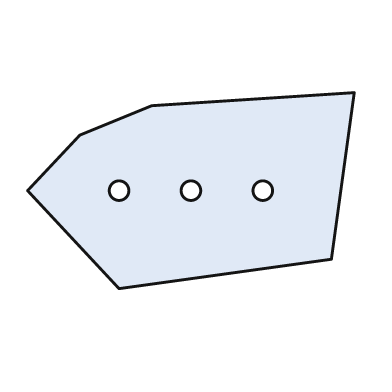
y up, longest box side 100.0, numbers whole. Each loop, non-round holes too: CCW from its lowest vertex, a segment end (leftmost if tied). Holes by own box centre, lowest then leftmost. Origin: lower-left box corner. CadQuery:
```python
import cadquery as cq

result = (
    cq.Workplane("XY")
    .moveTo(28.0, 0.0)
    .lineTo(93.0, 9.0)
    .lineTo(100.0, 60.0)
    .lineTo(38.0, 56.0)
    .lineTo(16.0, 47.0)
    .lineTo(0.0, 30.0)
    .close()
    .moveTo(28.0, 30.0)
    .circle(3.0)
    .moveTo(50.0, 30.0)
    .circle(3.0)
    .moveTo(72.0, 30.0)
    .circle(3.0)
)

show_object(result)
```